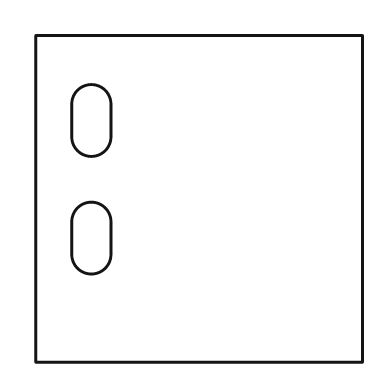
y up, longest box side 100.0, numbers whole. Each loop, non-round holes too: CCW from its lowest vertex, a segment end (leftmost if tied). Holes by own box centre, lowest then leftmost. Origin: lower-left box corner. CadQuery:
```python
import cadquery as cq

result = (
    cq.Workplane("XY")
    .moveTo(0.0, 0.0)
    .lineTo(100.0, 0.0)
    .lineTo(100.0, 100.0)
    .lineTo(0.0, 100.0)
    .close()
    .moveTo(11.0, 33.0)
    .threePointArc((17.0, 27.0), (23.0, 33.0))
    .lineTo(23.0, 43.0)
    .threePointArc((17.0, 49.0), (11.0, 43.0))
    .close()
    .moveTo(11.0, 69.0)
    .threePointArc((17.0, 63.0), (23.0, 69.0))
    .lineTo(23.0, 79.0)
    .threePointArc((17.0, 85.0), (11.0, 79.0))
    .close()
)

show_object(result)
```